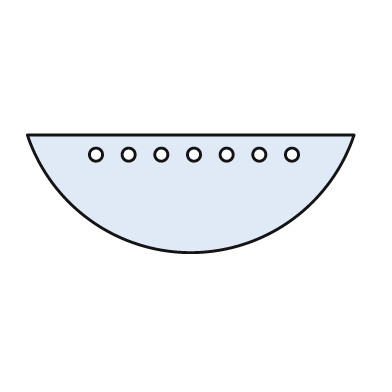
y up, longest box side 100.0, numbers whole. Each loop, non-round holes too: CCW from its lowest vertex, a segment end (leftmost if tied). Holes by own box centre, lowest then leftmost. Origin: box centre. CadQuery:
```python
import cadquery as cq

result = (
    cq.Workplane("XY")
    .moveTo(-50.0, 18.0)
    .threePointArc((0.0, -18.0), (50.0, 18.0))
    .close()
    .moveTo(-29.0, 12.0)
    .circle(2.0)
    .moveTo(-19.0, 12.0)
    .circle(2.0)
    .moveTo(-9.0, 12.0)
    .circle(2.0)
    .moveTo(1.0, 12.0)
    .circle(2.0)
    .moveTo(11.0, 12.0)
    .circle(2.0)
    .moveTo(21.0, 12.0)
    .circle(2.0)
    .moveTo(31.0, 12.0)
    .circle(2.0)
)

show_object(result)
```